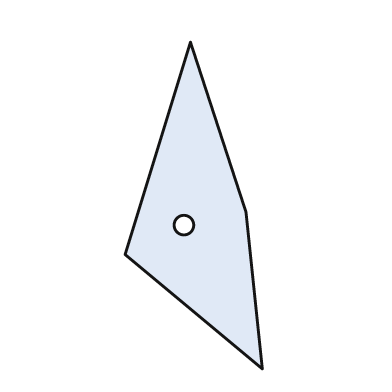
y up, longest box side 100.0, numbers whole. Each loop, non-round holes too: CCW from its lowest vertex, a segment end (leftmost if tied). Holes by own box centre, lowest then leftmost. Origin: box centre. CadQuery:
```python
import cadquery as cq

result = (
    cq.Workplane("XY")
    .moveTo(21.0, -50.0)
    .lineTo(16.0, -2.0)
    .lineTo(-1.0, 50.0)
    .lineTo(-21.0, -15.0)
    .close()
    .moveTo(-3.0, -6.0)
    .circle(3.0)
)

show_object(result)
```